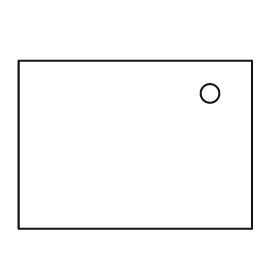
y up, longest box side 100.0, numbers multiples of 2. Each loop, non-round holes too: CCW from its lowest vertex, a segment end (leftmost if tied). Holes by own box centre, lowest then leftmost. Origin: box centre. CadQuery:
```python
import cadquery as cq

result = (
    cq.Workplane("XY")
    .moveTo(-50.0, -36.0)
    .lineTo(50.0, -36.0)
    .lineTo(50.0, 36.0)
    .lineTo(-50.0, 36.0)
    .close()
    .moveTo(32.0, 22.0)
    .circle(4.0)
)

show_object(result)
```